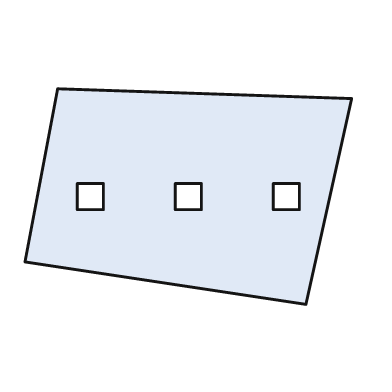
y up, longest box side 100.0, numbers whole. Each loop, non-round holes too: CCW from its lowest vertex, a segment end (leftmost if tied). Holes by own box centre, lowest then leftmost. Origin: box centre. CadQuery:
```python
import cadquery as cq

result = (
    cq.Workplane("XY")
    .moveTo(36.0, -33.0)
    .lineTo(50.0, 30.0)
    .lineTo(-40.0, 33.0)
    .lineTo(-50.0, -20.0)
    .close()
    .moveTo(-34.0, -4.0)
    .lineTo(-26.0, -4.0)
    .lineTo(-26.0, 4.0)
    .lineTo(-34.0, 4.0)
    .close()
    .moveTo(-4.0, -4.0)
    .lineTo(4.0, -4.0)
    .lineTo(4.0, 4.0)
    .lineTo(-4.0, 4.0)
    .close()
    .moveTo(26.0, -4.0)
    .lineTo(34.0, -4.0)
    .lineTo(34.0, 4.0)
    .lineTo(26.0, 4.0)
    .close()
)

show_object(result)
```